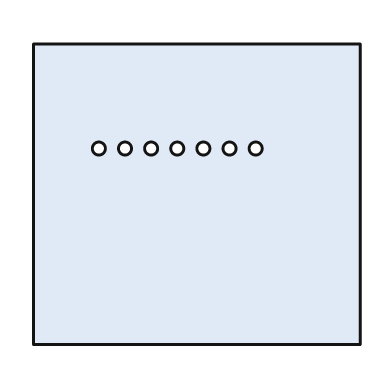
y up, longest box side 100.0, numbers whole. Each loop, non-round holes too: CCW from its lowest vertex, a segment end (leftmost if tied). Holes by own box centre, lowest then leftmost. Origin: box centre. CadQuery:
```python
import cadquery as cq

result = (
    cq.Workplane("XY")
    .moveTo(-50.0, -46.0)
    .lineTo(50.0, -46.0)
    .lineTo(50.0, 46.0)
    .lineTo(-50.0, 46.0)
    .close()
    .moveTo(-30.0, 14.0)
    .circle(2.0)
    .moveTo(-22.0, 14.0)
    .circle(2.0)
    .moveTo(-14.0, 14.0)
    .circle(2.0)
    .moveTo(-6.0, 14.0)
    .circle(2.0)
    .moveTo(2.0, 14.0)
    .circle(2.0)
    .moveTo(10.0, 14.0)
    .circle(2.0)
    .moveTo(18.0, 14.0)
    .circle(2.0)
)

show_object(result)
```